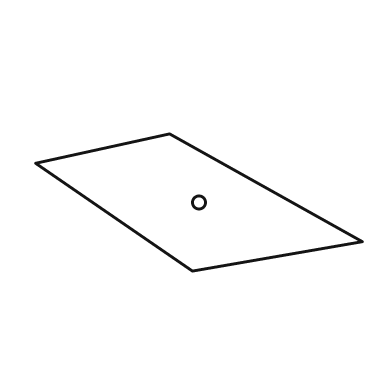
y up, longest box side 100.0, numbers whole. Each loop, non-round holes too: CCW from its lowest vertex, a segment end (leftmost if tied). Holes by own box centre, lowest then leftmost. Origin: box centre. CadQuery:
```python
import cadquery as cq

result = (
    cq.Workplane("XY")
    .moveTo(-2.0, -21.0)
    .lineTo(50.0, -12.0)
    .lineTo(-9.0, 21.0)
    .lineTo(-50.0, 12.0)
    .close()
    .moveTo(0.0, 0.0)
    .circle(2.0)
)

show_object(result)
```